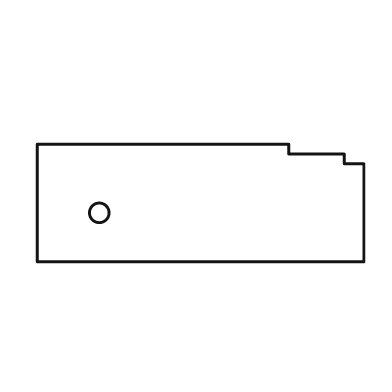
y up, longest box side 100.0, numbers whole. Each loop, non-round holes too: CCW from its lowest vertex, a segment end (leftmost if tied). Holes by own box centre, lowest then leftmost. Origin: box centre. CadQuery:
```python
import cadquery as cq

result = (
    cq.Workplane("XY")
    .moveTo(-50.0, -18.0)
    .lineTo(50.0, -18.0)
    .lineTo(50.0, 12.0)
    .lineTo(44.0, 12.0)
    .lineTo(44.0, 15.0)
    .lineTo(27.0, 15.0)
    .lineTo(27.0, 18.0)
    .lineTo(-50.0, 18.0)
    .close()
    .moveTo(-31.0, -3.0)
    .circle(3.0)
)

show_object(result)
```